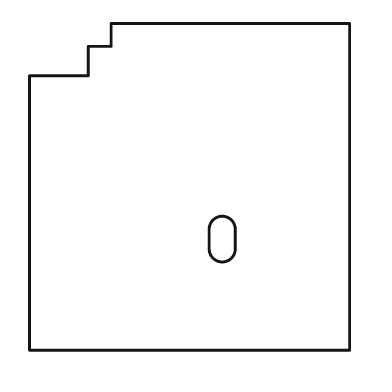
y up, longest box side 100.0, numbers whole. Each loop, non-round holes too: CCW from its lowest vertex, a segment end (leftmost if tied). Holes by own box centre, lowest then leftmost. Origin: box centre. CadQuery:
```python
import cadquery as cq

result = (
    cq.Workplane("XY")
    .moveTo(-49.0, -50.0)
    .lineTo(49.0, -50.0)
    .lineTo(49.0, 50.0)
    .lineTo(-24.0, 50.0)
    .lineTo(-24.0, 43.0)
    .lineTo(-31.0, 43.0)
    .lineTo(-31.0, 34.0)
    .lineTo(-49.0, 34.0)
    .close()
    .moveTo(6.0, -19.0)
    .threePointArc((10.0, -23.0), (14.0, -19.0))
    .lineTo(14.0, -13.0)
    .threePointArc((10.0, -9.0), (6.0, -13.0))
    .close()
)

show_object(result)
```